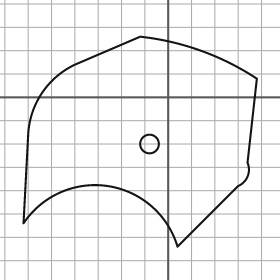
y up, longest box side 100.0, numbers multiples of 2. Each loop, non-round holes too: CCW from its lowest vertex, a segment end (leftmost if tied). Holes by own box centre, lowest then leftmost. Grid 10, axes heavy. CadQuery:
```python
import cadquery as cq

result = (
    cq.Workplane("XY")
    .moveTo(4.0, -64.0)
    .lineTo(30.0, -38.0)
    .threePointArc((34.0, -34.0), (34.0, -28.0))
    .lineTo(38.0, 8.0)
    .threePointArc((14.0, 20.0), (-12.0, 26.0))
    .lineTo(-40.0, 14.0)
    .threePointArc((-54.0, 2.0), (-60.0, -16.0))
    .lineTo(-62.0, -54.0)
    .threePointArc((-26.0, -38.0), (4.0, -64.0))
    .close()
    .moveTo(-8.0, -20.0)
    .circle(4.0)
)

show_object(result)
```